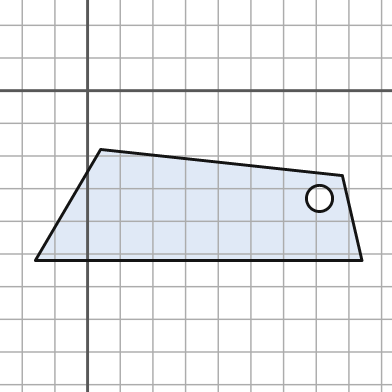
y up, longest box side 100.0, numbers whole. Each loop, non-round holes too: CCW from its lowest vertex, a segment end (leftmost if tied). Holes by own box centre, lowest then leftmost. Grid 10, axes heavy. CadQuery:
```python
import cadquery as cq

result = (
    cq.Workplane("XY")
    .moveTo(-16.0, -52.0)
    .lineTo(84.0, -52.0)
    .lineTo(78.0, -26.0)
    .lineTo(4.0, -18.0)
    .close()
    .moveTo(71.0, -33.0)
    .circle(4.0)
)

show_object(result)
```